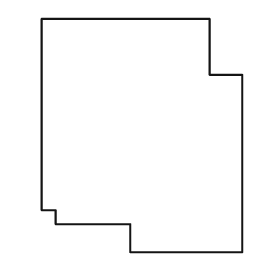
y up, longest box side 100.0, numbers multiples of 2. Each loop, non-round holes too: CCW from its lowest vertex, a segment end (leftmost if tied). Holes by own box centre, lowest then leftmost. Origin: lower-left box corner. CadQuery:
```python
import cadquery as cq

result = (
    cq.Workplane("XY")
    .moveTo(38.0, 0.0)
    .lineTo(86.0, 0.0)
    .lineTo(86.0, 76.0)
    .lineTo(72.0, 76.0)
    .lineTo(72.0, 100.0)
    .lineTo(0.0, 100.0)
    .lineTo(0.0, 18.0)
    .lineTo(6.0, 18.0)
    .lineTo(6.0, 12.0)
    .lineTo(38.0, 12.0)
    .close()
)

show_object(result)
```